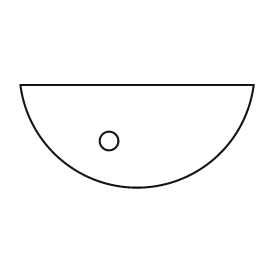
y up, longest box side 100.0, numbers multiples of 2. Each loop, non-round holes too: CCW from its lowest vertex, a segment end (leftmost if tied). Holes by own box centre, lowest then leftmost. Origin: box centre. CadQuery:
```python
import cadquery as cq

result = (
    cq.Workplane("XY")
    .moveTo(-50.0, 22.0)
    .threePointArc((0.0, -22.0), (50.0, 22.0))
    .close()
    .moveTo(-12.0, -2.0)
    .circle(4.0)
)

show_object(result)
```